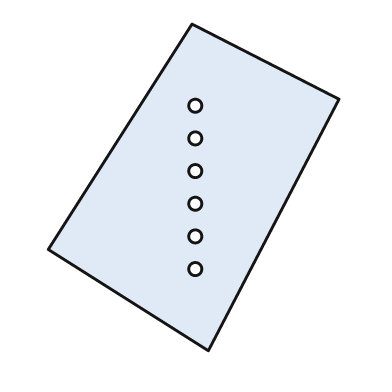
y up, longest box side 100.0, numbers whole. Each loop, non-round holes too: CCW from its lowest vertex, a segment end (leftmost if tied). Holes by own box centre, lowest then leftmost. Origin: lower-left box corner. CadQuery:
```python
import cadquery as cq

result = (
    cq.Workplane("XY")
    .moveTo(49.0, 0.0)
    .lineTo(89.0, 77.0)
    .lineTo(44.0, 100.0)
    .lineTo(0.0, 31.0)
    .close()
    .moveTo(45.0, 25.0)
    .circle(2.0)
    .moveTo(45.0, 35.0)
    .circle(2.0)
    .moveTo(45.0, 45.0)
    .circle(2.0)
    .moveTo(45.0, 55.0)
    .circle(2.0)
    .moveTo(45.0, 65.0)
    .circle(2.0)
    .moveTo(45.0, 75.0)
    .circle(2.0)
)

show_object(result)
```